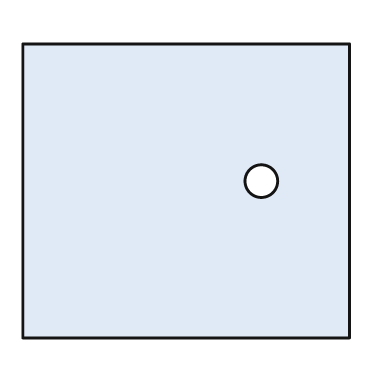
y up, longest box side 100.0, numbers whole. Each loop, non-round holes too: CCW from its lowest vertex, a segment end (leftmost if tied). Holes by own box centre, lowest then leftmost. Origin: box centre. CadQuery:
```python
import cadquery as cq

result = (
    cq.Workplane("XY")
    .moveTo(-50.0, -45.0)
    .lineTo(50.0, -45.0)
    .lineTo(50.0, 45.0)
    .lineTo(-50.0, 45.0)
    .close()
    .moveTo(23.0, 3.0)
    .circle(5.0)
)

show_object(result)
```